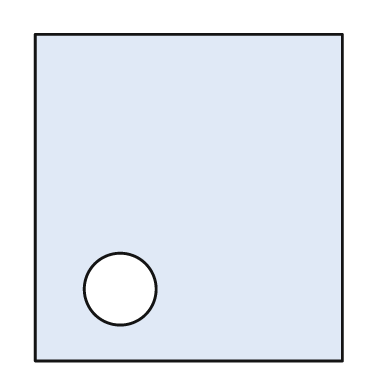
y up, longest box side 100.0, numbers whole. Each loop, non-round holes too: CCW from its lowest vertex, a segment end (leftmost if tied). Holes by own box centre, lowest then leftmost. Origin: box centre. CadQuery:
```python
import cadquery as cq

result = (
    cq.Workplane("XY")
    .moveTo(-47.0, -50.0)
    .lineTo(47.0, -50.0)
    .lineTo(47.0, 50.0)
    .lineTo(-47.0, 50.0)
    .close()
    .moveTo(-21.0, -28.0)
    .circle(11.0)
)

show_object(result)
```